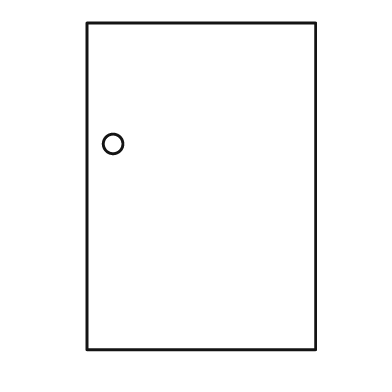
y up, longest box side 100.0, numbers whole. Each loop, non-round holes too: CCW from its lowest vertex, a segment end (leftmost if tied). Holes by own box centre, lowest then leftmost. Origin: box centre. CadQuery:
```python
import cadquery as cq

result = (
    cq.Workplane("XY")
    .moveTo(-35.0, -50.0)
    .lineTo(35.0, -50.0)
    .lineTo(35.0, 50.0)
    .lineTo(-35.0, 50.0)
    .close()
    .moveTo(-27.0, 13.0)
    .circle(3.0)
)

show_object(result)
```